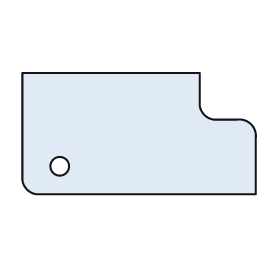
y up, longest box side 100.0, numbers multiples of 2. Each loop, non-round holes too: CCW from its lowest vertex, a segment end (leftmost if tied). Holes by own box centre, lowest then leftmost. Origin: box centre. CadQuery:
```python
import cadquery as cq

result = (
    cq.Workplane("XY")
    .moveTo(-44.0, -26.0)
    .lineTo(50.0, -26.0)
    .lineTo(50.0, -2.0)
    .threePointArc((48.0, 4.0), (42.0, 6.0))
    .lineTo(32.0, 6.0)
    .threePointArc((28.0, 8.0), (26.0, 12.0))
    .lineTo(26.0, 26.0)
    .lineTo(-50.0, 26.0)
    .lineTo(-50.0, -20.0)
    .threePointArc((-48.0, -24.0), (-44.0, -26.0))
    .close()
    .moveTo(-34.0, -14.0)
    .circle(4.0)
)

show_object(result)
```